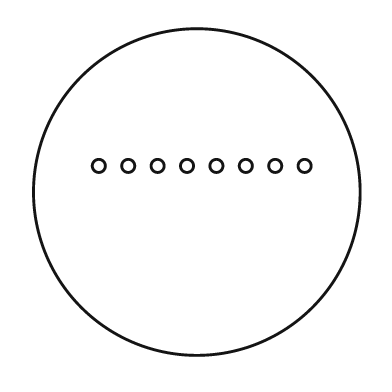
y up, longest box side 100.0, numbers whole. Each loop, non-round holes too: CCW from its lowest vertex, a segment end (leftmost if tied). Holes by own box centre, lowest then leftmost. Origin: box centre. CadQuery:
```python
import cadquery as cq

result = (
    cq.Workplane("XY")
    .moveTo(0.0, 0.0)
    .circle(50.0)
    .moveTo(-30.0, 8.0)
    .circle(2.0)
    .moveTo(-21.0, 8.0)
    .circle(2.0)
    .moveTo(-12.0, 8.0)
    .circle(2.0)
    .moveTo(-3.0, 8.0)
    .circle(2.0)
    .moveTo(6.0, 8.0)
    .circle(2.0)
    .moveTo(15.0, 8.0)
    .circle(2.0)
    .moveTo(24.0, 8.0)
    .circle(2.0)
    .moveTo(33.0, 8.0)
    .circle(2.0)
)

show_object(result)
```